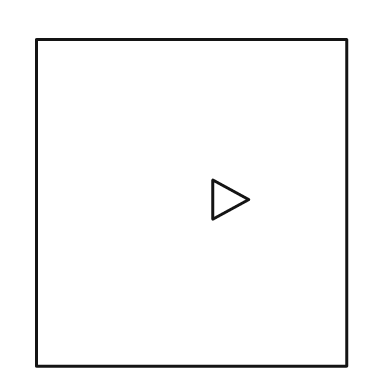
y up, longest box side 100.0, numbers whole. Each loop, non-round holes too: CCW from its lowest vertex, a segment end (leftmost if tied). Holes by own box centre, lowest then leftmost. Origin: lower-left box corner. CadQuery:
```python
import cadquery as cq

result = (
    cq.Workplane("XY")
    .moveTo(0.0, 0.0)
    .lineTo(95.0, 0.0)
    .lineTo(95.0, 100.0)
    .lineTo(0.0, 100.0)
    .close()
    .moveTo(54.0, 45.0)
    .lineTo(65.0, 51.0)
    .lineTo(54.0, 57.0)
    .close()
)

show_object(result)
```